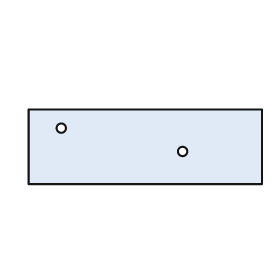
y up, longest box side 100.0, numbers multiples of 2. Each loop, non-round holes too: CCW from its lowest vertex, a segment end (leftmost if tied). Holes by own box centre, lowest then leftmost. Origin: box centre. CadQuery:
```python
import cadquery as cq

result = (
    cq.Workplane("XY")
    .moveTo(-50.0, -16.0)
    .lineTo(50.0, -16.0)
    .lineTo(50.0, 16.0)
    .lineTo(-50.0, 16.0)
    .close()
    .moveTo(16.0, -2.0)
    .circle(2.0)
    .moveTo(-36.0, 8.0)
    .circle(2.0)
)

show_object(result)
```